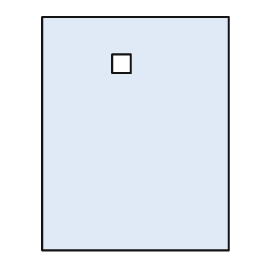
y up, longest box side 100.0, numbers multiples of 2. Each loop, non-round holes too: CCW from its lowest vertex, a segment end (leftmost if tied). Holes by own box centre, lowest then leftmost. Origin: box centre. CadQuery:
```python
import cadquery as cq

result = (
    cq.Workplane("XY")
    .moveTo(-40.0, -50.0)
    .lineTo(40.0, -50.0)
    .lineTo(40.0, 50.0)
    .lineTo(-40.0, 50.0)
    .close()
    .moveTo(-10.0, 26.0)
    .lineTo(-2.0, 26.0)
    .lineTo(-2.0, 34.0)
    .lineTo(-10.0, 34.0)
    .close()
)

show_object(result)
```